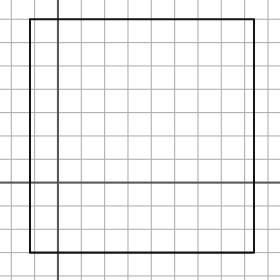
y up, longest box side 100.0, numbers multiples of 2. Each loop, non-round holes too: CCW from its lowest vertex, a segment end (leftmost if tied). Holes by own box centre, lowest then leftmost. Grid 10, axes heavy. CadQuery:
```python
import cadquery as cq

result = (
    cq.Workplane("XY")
    .moveTo(-12.0, -30.0)
    .lineTo(84.0, -30.0)
    .lineTo(84.0, 70.0)
    .lineTo(-12.0, 70.0)
    .close()
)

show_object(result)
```